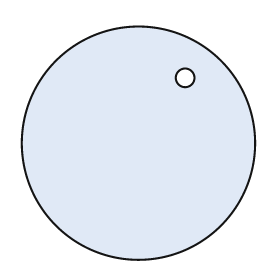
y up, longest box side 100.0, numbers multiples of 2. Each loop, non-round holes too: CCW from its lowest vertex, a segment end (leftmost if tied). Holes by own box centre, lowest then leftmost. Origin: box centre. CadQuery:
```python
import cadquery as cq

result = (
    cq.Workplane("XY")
    .moveTo(0.0, 0.0)
    .circle(50.0)
    .moveTo(20.0, 28.0)
    .circle(4.0)
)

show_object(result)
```